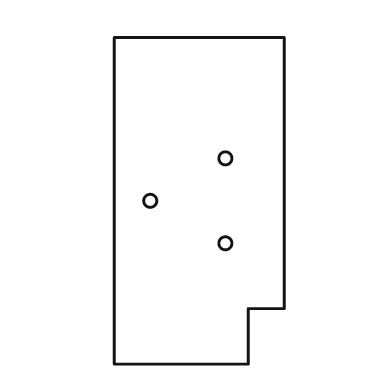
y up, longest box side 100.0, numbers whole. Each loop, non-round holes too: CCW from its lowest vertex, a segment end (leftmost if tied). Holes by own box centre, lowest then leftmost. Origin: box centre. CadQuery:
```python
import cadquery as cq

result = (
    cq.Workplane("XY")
    .moveTo(-26.0, -50.0)
    .lineTo(15.0, -50.0)
    .lineTo(15.0, -33.0)
    .lineTo(26.0, -33.0)
    .lineTo(26.0, 50.0)
    .lineTo(-26.0, 50.0)
    .close()
    .moveTo(8.0, -13.0)
    .circle(2.0)
    .moveTo(-15.0, 0.0)
    .circle(2.0)
    .moveTo(8.0, 13.0)
    .circle(2.0)
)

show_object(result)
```